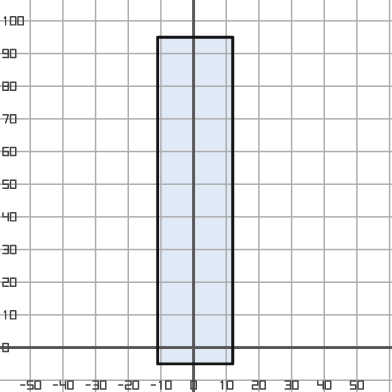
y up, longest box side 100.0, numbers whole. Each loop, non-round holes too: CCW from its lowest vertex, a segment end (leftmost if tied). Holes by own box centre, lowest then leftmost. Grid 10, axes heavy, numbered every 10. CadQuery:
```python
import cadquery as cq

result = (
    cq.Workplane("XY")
    .moveTo(-11.0, -5.0)
    .lineTo(12.0, -5.0)
    .lineTo(12.0, 95.0)
    .lineTo(-11.0, 95.0)
    .close()
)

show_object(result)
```